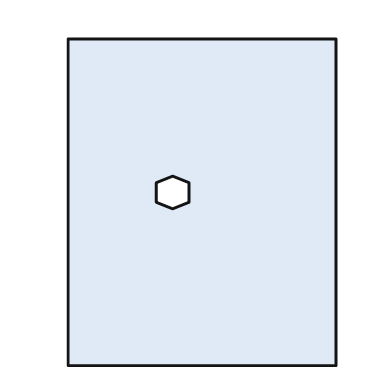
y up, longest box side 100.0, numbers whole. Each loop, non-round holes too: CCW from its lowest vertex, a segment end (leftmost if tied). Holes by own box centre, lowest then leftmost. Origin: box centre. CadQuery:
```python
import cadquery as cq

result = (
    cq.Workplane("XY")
    .moveTo(-41.0, -50.0)
    .lineTo(41.0, -50.0)
    .lineTo(41.0, 50.0)
    .lineTo(-41.0, 50.0)
    .close()
    .moveTo(-9.0, -2.0)
    .lineTo(-4.0, 0.0)
    .lineTo(-4.0, 6.0)
    .lineTo(-9.0, 8.0)
    .lineTo(-14.0, 6.0)
    .lineTo(-14.0, 0.0)
    .close()
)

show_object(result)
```